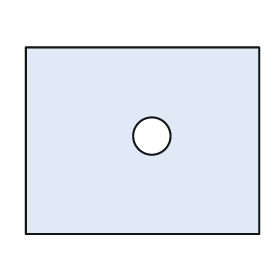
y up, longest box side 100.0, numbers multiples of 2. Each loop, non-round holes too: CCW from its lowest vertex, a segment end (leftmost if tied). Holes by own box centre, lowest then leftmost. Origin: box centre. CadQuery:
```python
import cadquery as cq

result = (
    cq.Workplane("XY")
    .moveTo(-50.0, -40.0)
    .lineTo(50.0, -40.0)
    .lineTo(50.0, 40.0)
    .lineTo(-50.0, 40.0)
    .close()
    .moveTo(4.0, 2.0)
    .circle(8.0)
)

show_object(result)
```